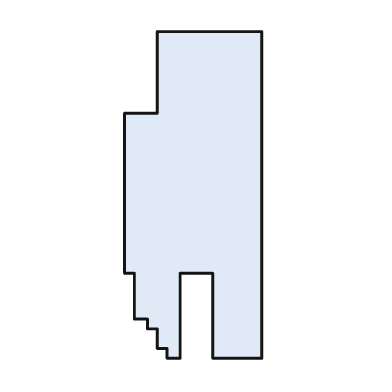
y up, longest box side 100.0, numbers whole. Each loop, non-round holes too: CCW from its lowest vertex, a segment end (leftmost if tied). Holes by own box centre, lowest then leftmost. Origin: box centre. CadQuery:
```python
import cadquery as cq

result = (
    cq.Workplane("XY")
    .moveTo(-8.0, -50.0)
    .lineTo(-4.0, -50.0)
    .lineTo(-4.0, -24.0)
    .lineTo(6.0, -24.0)
    .lineTo(6.0, -50.0)
    .lineTo(21.0, -50.0)
    .lineTo(21.0, 50.0)
    .lineTo(-11.0, 50.0)
    .lineTo(-11.0, 25.0)
    .lineTo(-21.0, 25.0)
    .lineTo(-21.0, -24.0)
    .lineTo(-18.0, -24.0)
    .lineTo(-18.0, -38.0)
    .lineTo(-14.0, -38.0)
    .lineTo(-14.0, -41.0)
    .lineTo(-11.0, -41.0)
    .lineTo(-11.0, -47.0)
    .lineTo(-8.0, -47.0)
    .close()
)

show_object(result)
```